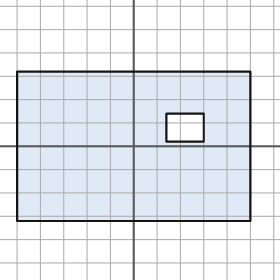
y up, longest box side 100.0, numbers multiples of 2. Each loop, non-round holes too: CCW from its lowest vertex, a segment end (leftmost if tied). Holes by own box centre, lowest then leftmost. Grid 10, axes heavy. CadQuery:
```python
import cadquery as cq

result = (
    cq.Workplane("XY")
    .moveTo(-50.0, -32.0)
    .lineTo(50.0, -32.0)
    .lineTo(50.0, 32.0)
    .lineTo(-50.0, 32.0)
    .close()
    .moveTo(14.0, 2.0)
    .lineTo(30.0, 2.0)
    .lineTo(30.0, 14.0)
    .lineTo(14.0, 14.0)
    .close()
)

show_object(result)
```